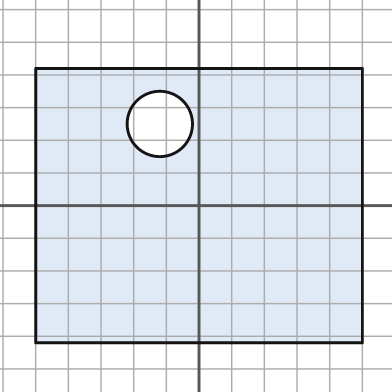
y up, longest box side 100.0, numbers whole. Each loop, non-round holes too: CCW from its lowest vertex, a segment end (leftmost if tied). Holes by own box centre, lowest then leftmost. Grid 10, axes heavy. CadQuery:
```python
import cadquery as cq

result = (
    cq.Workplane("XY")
    .moveTo(-50.0, -42.0)
    .lineTo(50.0, -42.0)
    .lineTo(50.0, 42.0)
    .lineTo(-50.0, 42.0)
    .close()
    .moveTo(-12.0, 25.0)
    .circle(10.0)
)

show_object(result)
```